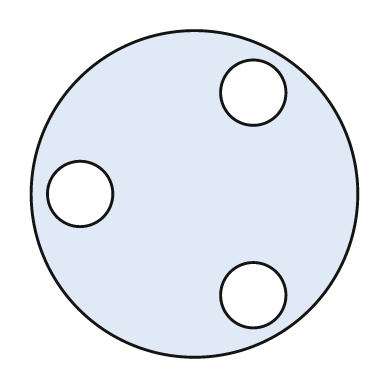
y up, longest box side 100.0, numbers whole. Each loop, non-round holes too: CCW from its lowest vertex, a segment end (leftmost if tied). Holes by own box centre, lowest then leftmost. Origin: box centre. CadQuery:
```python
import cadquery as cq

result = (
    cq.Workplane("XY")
    .moveTo(0.0, 0.0)
    .circle(50.0)
    .moveTo(18.0, -31.0)
    .circle(10.0)
    .moveTo(-35.0, 0.0)
    .circle(10.0)
    .moveTo(18.0, 31.0)
    .circle(10.0)
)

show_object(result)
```